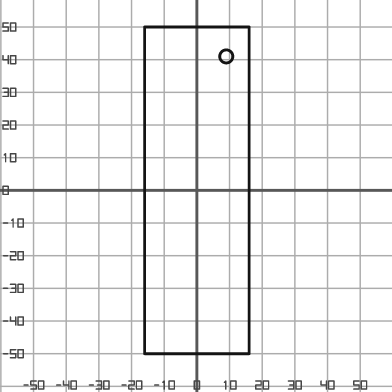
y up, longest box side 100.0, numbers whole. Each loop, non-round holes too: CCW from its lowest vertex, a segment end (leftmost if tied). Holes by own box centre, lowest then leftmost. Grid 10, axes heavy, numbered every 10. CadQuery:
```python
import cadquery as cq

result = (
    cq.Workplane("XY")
    .moveTo(-16.0, -50.0)
    .lineTo(16.0, -50.0)
    .lineTo(16.0, 50.0)
    .lineTo(-16.0, 50.0)
    .close()
    .moveTo(9.0, 41.0)
    .circle(2.0)
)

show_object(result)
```